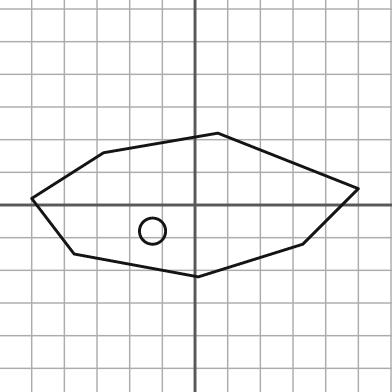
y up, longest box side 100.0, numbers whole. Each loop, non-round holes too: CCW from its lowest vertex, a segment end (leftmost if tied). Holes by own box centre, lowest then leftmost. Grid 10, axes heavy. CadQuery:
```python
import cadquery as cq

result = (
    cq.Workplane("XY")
    .moveTo(1.0, -22.0)
    .lineTo(33.0, -12.0)
    .lineTo(50.0, 5.0)
    .lineTo(7.0, 22.0)
    .lineTo(-28.0, 16.0)
    .lineTo(-50.0, 2.0)
    .lineTo(-37.0, -15.0)
    .close()
    .moveTo(-13.0, -8.0)
    .circle(4.0)
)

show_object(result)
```